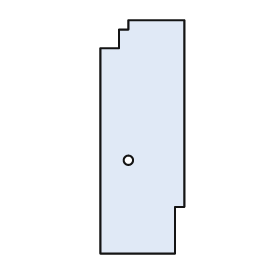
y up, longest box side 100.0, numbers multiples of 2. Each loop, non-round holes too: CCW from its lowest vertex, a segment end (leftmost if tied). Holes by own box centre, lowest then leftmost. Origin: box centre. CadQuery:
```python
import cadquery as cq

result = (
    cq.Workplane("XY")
    .moveTo(-18.0, -50.0)
    .lineTo(14.0, -50.0)
    .lineTo(14.0, -30.0)
    .lineTo(18.0, -30.0)
    .lineTo(18.0, 50.0)
    .lineTo(-6.0, 50.0)
    .lineTo(-6.0, 46.0)
    .lineTo(-10.0, 46.0)
    .lineTo(-10.0, 38.0)
    .lineTo(-18.0, 38.0)
    .close()
    .moveTo(-6.0, -10.0)
    .circle(2.0)
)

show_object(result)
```